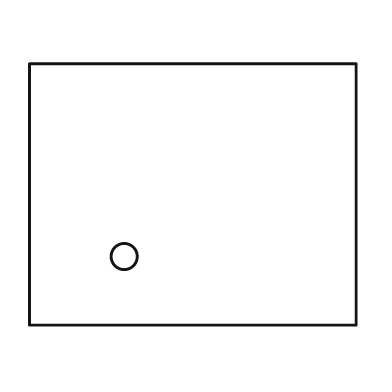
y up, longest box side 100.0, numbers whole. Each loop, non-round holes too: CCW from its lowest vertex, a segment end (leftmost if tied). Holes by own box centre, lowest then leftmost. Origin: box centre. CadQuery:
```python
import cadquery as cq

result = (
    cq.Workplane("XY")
    .moveTo(-50.0, -40.0)
    .lineTo(50.0, -40.0)
    .lineTo(50.0, 40.0)
    .lineTo(-50.0, 40.0)
    .close()
    .moveTo(-21.0, -19.0)
    .circle(4.0)
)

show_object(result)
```